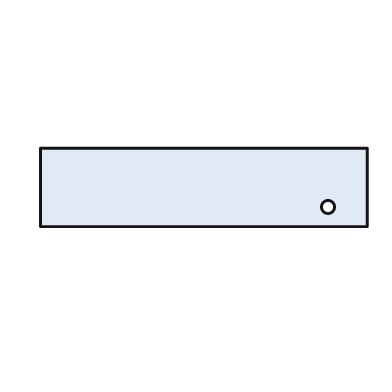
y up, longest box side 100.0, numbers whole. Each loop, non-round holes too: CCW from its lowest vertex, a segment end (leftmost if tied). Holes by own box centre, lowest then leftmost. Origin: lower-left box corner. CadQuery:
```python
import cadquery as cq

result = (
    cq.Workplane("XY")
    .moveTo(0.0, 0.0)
    .lineTo(100.0, 0.0)
    .lineTo(100.0, 24.0)
    .lineTo(0.0, 24.0)
    .close()
    .moveTo(88.0, 6.0)
    .circle(2.0)
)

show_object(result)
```